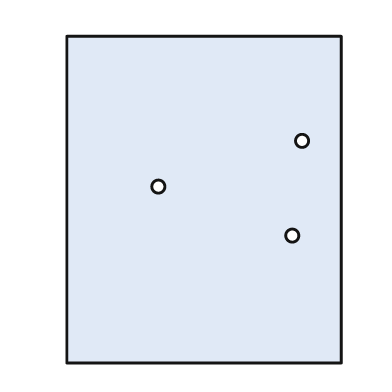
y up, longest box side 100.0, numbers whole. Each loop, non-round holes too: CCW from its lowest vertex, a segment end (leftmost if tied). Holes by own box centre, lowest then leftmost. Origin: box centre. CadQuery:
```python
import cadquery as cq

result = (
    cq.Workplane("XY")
    .moveTo(-42.0, -50.0)
    .lineTo(42.0, -50.0)
    .lineTo(42.0, 50.0)
    .lineTo(-42.0, 50.0)
    .close()
    .moveTo(27.0, -11.0)
    .circle(2.0)
    .moveTo(-14.0, 4.0)
    .circle(2.0)
    .moveTo(30.0, 18.0)
    .circle(2.0)
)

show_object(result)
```